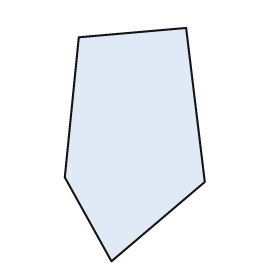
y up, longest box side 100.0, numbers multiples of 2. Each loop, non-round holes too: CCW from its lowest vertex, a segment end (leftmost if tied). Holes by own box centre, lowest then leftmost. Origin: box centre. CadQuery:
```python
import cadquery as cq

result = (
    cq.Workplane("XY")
    .moveTo(-10.0, -50.0)
    .lineTo(30.0, -16.0)
    .lineTo(22.0, 50.0)
    .lineTo(-24.0, 46.0)
    .lineTo(-30.0, -14.0)
    .close()
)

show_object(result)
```